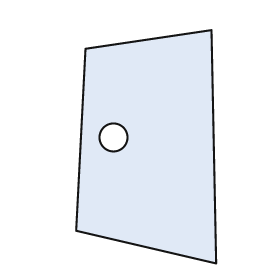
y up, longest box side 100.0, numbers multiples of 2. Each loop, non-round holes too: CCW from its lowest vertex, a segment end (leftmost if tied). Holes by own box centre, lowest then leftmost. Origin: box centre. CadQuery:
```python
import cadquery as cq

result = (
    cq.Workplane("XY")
    .moveTo(30.0, -50.0)
    .lineTo(28.0, 50.0)
    .lineTo(-26.0, 42.0)
    .lineTo(-30.0, -36.0)
    .close()
    .moveTo(-14.0, 4.0)
    .circle(6.0)
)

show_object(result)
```